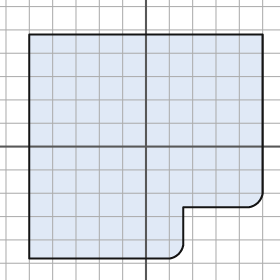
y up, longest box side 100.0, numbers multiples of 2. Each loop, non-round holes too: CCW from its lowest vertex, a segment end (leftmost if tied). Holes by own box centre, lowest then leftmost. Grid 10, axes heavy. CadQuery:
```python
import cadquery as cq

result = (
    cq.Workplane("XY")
    .moveTo(-50.0, -48.0)
    .lineTo(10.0, -48.0)
    .threePointArc((14.0, -46.0), (16.0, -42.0))
    .lineTo(16.0, -26.0)
    .lineTo(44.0, -26.0)
    .threePointArc((48.0, -24.0), (50.0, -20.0))
    .lineTo(50.0, 48.0)
    .lineTo(-50.0, 48.0)
    .close()
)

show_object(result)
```